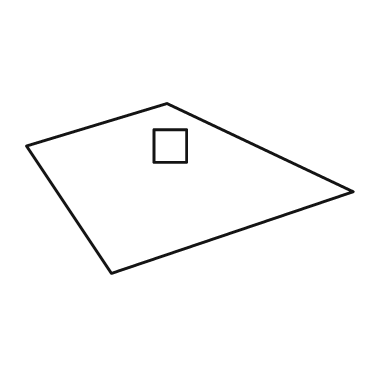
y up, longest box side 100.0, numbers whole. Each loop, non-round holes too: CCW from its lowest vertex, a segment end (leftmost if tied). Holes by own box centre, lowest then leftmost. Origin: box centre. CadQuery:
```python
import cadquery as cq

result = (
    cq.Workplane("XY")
    .moveTo(-24.0, -26.0)
    .lineTo(50.0, -1.0)
    .lineTo(-7.0, 26.0)
    .lineTo(-50.0, 13.0)
    .close()
    .moveTo(-11.0, 8.0)
    .lineTo(-1.0, 8.0)
    .lineTo(-1.0, 18.0)
    .lineTo(-11.0, 18.0)
    .close()
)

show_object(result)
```